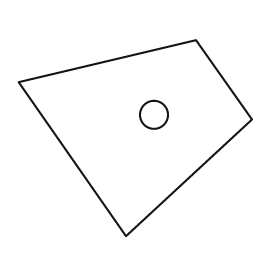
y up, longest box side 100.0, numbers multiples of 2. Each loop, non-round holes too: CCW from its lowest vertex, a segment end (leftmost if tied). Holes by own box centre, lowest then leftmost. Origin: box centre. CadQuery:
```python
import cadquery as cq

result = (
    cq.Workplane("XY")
    .moveTo(-4.0, -42.0)
    .lineTo(50.0, 8.0)
    .lineTo(26.0, 42.0)
    .lineTo(-50.0, 24.0)
    .close()
    .moveTo(8.0, 10.0)
    .circle(6.0)
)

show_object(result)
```